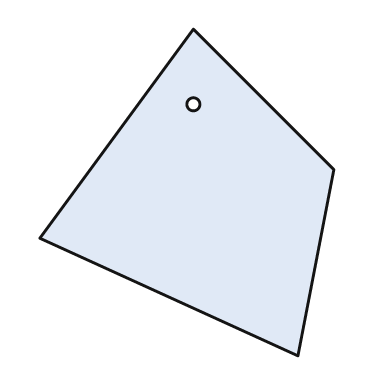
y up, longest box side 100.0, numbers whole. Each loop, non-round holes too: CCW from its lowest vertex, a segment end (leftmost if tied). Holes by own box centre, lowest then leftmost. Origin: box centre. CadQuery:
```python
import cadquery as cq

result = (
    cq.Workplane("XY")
    .moveTo(34.0, -50.0)
    .lineTo(45.0, 7.0)
    .lineTo(2.0, 50.0)
    .lineTo(-45.0, -14.0)
    .close()
    .moveTo(2.0, 27.0)
    .circle(2.0)
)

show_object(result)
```